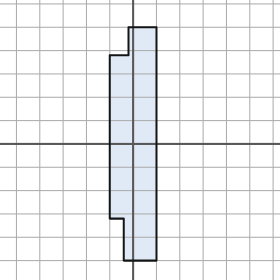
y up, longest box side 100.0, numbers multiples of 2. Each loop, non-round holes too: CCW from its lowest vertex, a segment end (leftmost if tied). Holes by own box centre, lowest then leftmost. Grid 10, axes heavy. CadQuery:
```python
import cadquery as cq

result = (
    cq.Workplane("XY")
    .moveTo(-4.0, -50.0)
    .lineTo(10.0, -50.0)
    .lineTo(10.0, 50.0)
    .lineTo(-2.0, 50.0)
    .lineTo(-2.0, 38.0)
    .lineTo(-10.0, 38.0)
    .lineTo(-10.0, -32.0)
    .lineTo(-4.0, -32.0)
    .close()
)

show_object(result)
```